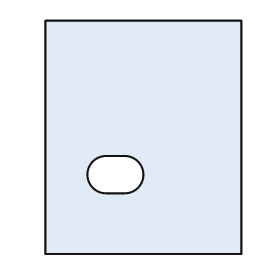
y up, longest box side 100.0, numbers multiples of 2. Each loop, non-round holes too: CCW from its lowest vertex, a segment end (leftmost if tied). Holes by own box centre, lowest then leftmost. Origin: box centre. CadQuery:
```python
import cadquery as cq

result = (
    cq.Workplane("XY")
    .moveTo(-42.0, -50.0)
    .lineTo(42.0, -50.0)
    .lineTo(42.0, 50.0)
    .lineTo(-42.0, 50.0)
    .close()
    .moveTo(-16.0, -24.0)
    .lineTo(-8.0, -24.0)
    .threePointArc((0.0, -16.0), (-8.0, -8.0))
    .lineTo(-16.0, -8.0)
    .threePointArc((-24.0, -16.0), (-16.0, -24.0))
    .close()
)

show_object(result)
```